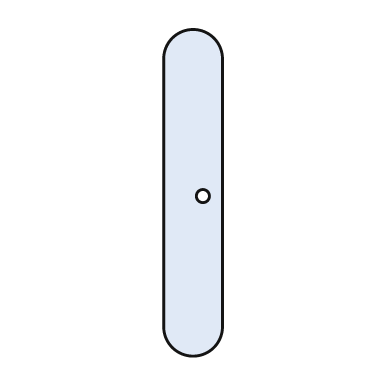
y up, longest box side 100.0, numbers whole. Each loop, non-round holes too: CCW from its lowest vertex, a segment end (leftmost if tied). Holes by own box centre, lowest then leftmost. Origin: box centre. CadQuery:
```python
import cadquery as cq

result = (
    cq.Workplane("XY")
    .moveTo(-9.0, -41.0)
    .threePointArc((0.0, -50.0), (9.0, -41.0))
    .lineTo(9.0, 41.0)
    .threePointArc((0.0, 50.0), (-9.0, 41.0))
    .close()
    .moveTo(3.0, -1.0)
    .circle(2.0)
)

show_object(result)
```